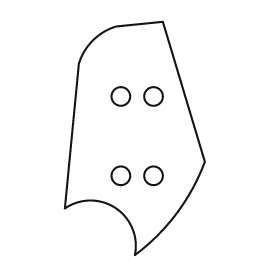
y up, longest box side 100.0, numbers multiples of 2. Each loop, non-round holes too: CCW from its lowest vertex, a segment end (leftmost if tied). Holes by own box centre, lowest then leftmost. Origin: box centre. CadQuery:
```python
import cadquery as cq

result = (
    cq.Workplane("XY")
    .moveTo(0.0, -50.0)
    .threePointArc((18.0, -32.0), (30.0, -10.0))
    .lineTo(12.0, 50.0)
    .lineTo(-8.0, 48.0)
    .threePointArc((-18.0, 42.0), (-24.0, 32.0))
    .lineTo(-30.0, -30.0)
    .threePointArc((-8.0, -30.0), (0.0, -50.0))
    .close()
    .moveTo(-6.0, -16.0)
    .circle(4.0)
    .moveTo(8.0, -16.0)
    .circle(4.0)
    .moveTo(-6.0, 18.0)
    .circle(4.0)
    .moveTo(8.0, 18.0)
    .circle(4.0)
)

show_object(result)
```